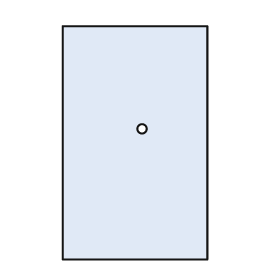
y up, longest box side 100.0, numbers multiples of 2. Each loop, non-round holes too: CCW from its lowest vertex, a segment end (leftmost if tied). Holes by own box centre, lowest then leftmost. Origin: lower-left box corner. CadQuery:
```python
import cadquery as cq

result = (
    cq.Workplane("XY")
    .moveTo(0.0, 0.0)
    .lineTo(62.0, 0.0)
    .lineTo(62.0, 100.0)
    .lineTo(0.0, 100.0)
    .close()
    .moveTo(34.0, 56.0)
    .circle(2.0)
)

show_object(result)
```